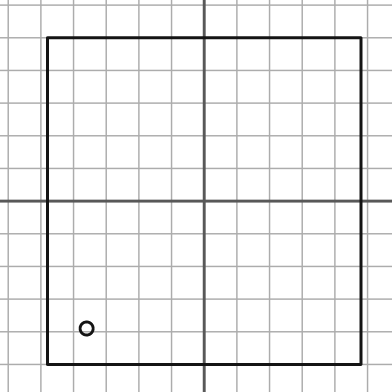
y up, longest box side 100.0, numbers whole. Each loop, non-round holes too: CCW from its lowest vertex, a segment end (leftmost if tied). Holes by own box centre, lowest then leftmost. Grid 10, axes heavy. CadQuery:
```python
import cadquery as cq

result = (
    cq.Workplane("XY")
    .moveTo(-48.0, -50.0)
    .lineTo(48.0, -50.0)
    .lineTo(48.0, 50.0)
    .lineTo(-48.0, 50.0)
    .close()
    .moveTo(-36.0, -39.0)
    .circle(2.0)
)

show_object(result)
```